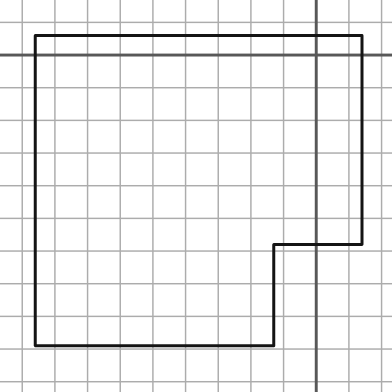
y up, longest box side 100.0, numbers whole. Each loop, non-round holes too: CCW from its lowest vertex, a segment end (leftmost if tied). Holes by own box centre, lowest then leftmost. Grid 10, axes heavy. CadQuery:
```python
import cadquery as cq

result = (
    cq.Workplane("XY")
    .moveTo(-86.0, -89.0)
    .lineTo(-13.0, -89.0)
    .lineTo(-13.0, -58.0)
    .lineTo(14.0, -58.0)
    .lineTo(14.0, 6.0)
    .lineTo(-86.0, 6.0)
    .close()
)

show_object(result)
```